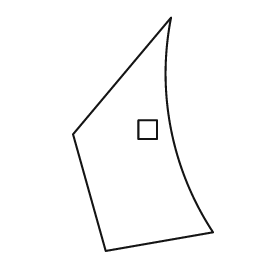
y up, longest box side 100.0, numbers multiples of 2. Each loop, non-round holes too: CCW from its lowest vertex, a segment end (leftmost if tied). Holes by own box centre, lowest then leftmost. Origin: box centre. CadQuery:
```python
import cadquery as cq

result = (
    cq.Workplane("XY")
    .moveTo(-16.0, -50.0)
    .lineTo(30.0, -42.0)
    .threePointArc((12.0, 2.0), (12.0, 50.0))
    .lineTo(-30.0, 0.0)
    .close()
    .moveTo(-2.0, -2.0)
    .lineTo(6.0, -2.0)
    .lineTo(6.0, 6.0)
    .lineTo(-2.0, 6.0)
    .close()
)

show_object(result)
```